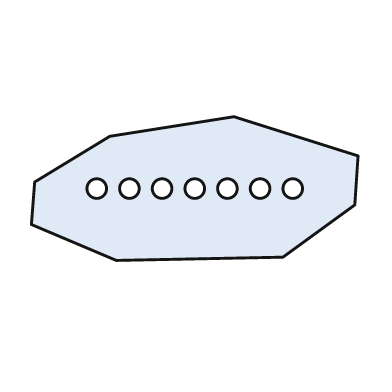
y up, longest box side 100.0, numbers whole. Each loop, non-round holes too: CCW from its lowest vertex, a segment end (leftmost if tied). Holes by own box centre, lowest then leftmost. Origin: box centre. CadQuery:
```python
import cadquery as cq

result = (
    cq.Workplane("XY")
    .moveTo(-24.0, -22.0)
    .lineTo(27.0, -21.0)
    .lineTo(49.0, -5.0)
    .lineTo(50.0, 10.0)
    .lineTo(12.0, 22.0)
    .lineTo(-26.0, 16.0)
    .lineTo(-49.0, 2.0)
    .lineTo(-50.0, -11.0)
    .close()
    .moveTo(-30.0, 0.0)
    .circle(3.0)
    .moveTo(-20.0, 0.0)
    .circle(3.0)
    .moveTo(-10.0, 0.0)
    .circle(3.0)
    .moveTo(0.0, 0.0)
    .circle(3.0)
    .moveTo(10.0, 0.0)
    .circle(3.0)
    .moveTo(20.0, 0.0)
    .circle(3.0)
    .moveTo(30.0, 0.0)
    .circle(3.0)
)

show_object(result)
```